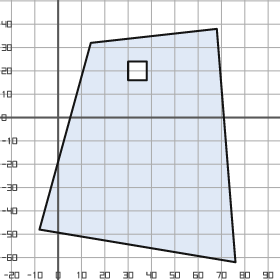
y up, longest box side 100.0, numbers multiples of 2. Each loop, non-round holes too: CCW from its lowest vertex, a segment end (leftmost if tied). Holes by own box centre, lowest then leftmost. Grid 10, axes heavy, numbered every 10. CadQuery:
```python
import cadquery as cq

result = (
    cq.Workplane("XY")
    .moveTo(76.0, -62.0)
    .lineTo(68.0, 38.0)
    .lineTo(14.0, 32.0)
    .lineTo(-8.0, -48.0)
    .close()
    .moveTo(30.0, 16.0)
    .lineTo(38.0, 16.0)
    .lineTo(38.0, 24.0)
    .lineTo(30.0, 24.0)
    .close()
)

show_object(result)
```